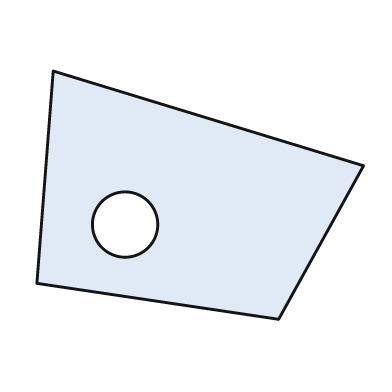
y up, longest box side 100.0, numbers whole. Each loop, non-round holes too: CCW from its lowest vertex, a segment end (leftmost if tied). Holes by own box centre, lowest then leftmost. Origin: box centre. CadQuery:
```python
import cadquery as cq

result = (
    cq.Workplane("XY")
    .moveTo(24.0, -38.0)
    .lineTo(50.0, 9.0)
    .lineTo(-45.0, 38.0)
    .lineTo(-50.0, -27.0)
    .close()
    .moveTo(-23.0, -9.0)
    .circle(10.0)
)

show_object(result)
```